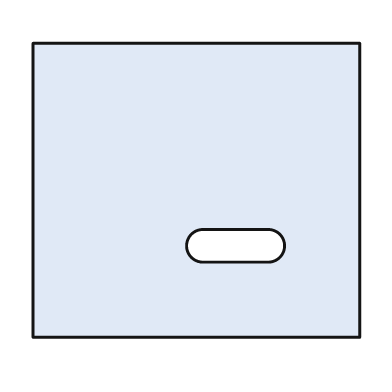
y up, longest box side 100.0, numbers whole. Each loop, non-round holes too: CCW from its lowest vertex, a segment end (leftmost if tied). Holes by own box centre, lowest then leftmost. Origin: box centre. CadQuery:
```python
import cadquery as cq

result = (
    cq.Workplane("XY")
    .moveTo(-50.0, -45.0)
    .lineTo(50.0, -45.0)
    .lineTo(50.0, 45.0)
    .lineTo(-50.0, 45.0)
    .close()
    .moveTo(2.0, -22.0)
    .lineTo(22.0, -22.0)
    .threePointArc((27.0, -17.0), (22.0, -12.0))
    .lineTo(2.0, -12.0)
    .threePointArc((-3.0, -17.0), (2.0, -22.0))
    .close()
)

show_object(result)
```